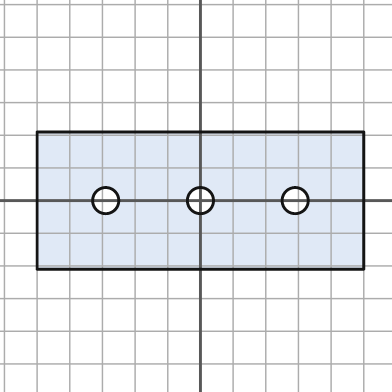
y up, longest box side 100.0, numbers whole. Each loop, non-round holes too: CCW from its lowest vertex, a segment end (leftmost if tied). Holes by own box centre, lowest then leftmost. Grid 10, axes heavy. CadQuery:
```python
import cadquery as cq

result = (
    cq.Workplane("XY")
    .moveTo(-50.0, -21.0)
    .lineTo(50.0, -21.0)
    .lineTo(50.0, 21.0)
    .lineTo(-50.0, 21.0)
    .close()
    .moveTo(-29.0, 0.0)
    .circle(4.0)
    .moveTo(0.0, 0.0)
    .circle(4.0)
    .moveTo(29.0, 0.0)
    .circle(4.0)
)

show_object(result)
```